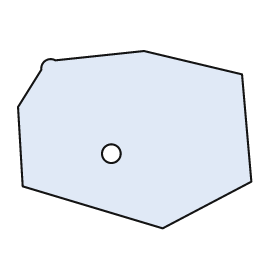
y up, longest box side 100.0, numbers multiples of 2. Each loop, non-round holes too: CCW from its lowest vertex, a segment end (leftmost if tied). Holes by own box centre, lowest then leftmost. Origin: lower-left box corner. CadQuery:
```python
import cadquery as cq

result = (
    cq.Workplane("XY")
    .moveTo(62.0, 0.0)
    .lineTo(100.0, 20.0)
    .lineTo(96.0, 66.0)
    .lineTo(54.0, 76.0)
    .lineTo(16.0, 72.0)
    .threePointArc((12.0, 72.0), (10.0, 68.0))
    .lineTo(0.0, 52.0)
    .lineTo(2.0, 18.0)
    .close()
    .moveTo(40.0, 32.0)
    .circle(4.0)
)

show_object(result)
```